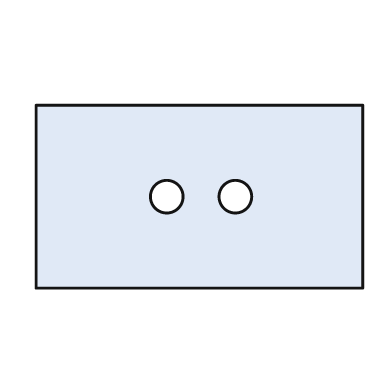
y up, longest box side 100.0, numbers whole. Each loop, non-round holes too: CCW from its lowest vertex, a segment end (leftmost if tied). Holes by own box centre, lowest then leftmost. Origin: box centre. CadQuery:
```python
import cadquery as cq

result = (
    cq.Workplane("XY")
    .moveTo(-50.0, -28.0)
    .lineTo(50.0, -28.0)
    .lineTo(50.0, 28.0)
    .lineTo(-50.0, 28.0)
    .close()
    .moveTo(-10.0, 0.0)
    .circle(5.0)
    .moveTo(11.0, 0.0)
    .circle(5.0)
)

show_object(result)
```